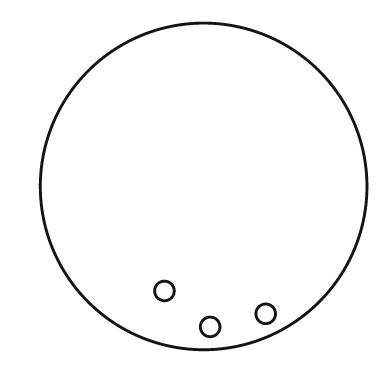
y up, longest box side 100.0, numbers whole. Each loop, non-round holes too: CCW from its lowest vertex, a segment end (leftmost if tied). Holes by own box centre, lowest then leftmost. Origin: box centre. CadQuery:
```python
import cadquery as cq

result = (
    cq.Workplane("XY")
    .moveTo(0.0, 0.0)
    .circle(50.0)
    .moveTo(2.0, -43.0)
    .circle(3.0)
    .moveTo(19.0, -39.0)
    .circle(3.0)
    .moveTo(-12.0, -32.0)
    .circle(3.0)
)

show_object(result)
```